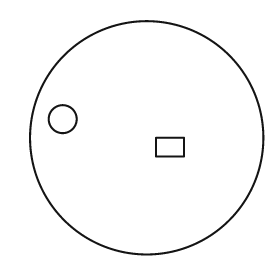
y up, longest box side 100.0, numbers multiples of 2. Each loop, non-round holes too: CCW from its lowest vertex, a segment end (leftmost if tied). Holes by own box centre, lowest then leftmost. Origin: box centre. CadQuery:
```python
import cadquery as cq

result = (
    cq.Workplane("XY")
    .moveTo(0.0, 0.0)
    .circle(50.0)
    .moveTo(4.0, -8.0)
    .lineTo(16.0, -8.0)
    .lineTo(16.0, 0.0)
    .lineTo(4.0, 0.0)
    .close()
    .moveTo(-36.0, 8.0)
    .circle(6.0)
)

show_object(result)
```